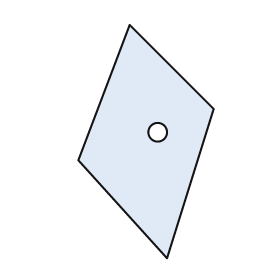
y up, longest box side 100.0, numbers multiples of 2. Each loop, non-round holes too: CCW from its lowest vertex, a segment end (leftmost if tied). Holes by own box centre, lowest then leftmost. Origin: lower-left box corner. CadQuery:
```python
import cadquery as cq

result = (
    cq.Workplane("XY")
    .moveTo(38.0, 0.0)
    .lineTo(58.0, 64.0)
    .lineTo(22.0, 100.0)
    .lineTo(0.0, 42.0)
    .close()
    .moveTo(34.0, 54.0)
    .circle(4.0)
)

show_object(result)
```